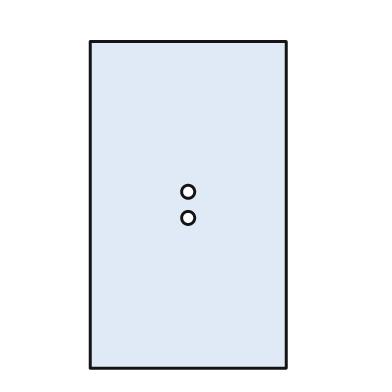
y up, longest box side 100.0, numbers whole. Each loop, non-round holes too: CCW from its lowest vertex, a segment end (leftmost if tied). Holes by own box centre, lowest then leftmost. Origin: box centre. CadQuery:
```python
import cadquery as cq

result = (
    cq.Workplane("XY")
    .moveTo(-30.0, -50.0)
    .lineTo(30.0, -50.0)
    .lineTo(30.0, 50.0)
    .lineTo(-30.0, 50.0)
    .close()
    .moveTo(0.0, -4.0)
    .circle(2.0)
    .moveTo(0.0, 4.0)
    .circle(2.0)
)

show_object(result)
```